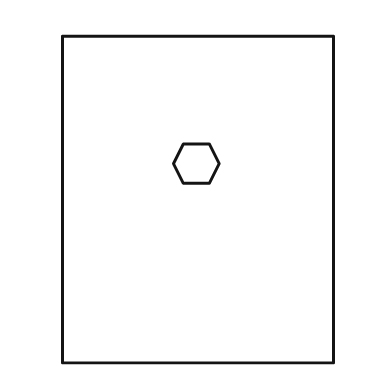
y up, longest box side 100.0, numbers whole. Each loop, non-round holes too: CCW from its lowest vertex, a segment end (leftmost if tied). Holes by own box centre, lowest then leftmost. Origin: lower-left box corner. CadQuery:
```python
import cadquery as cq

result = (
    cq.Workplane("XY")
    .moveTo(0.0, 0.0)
    .lineTo(83.0, 0.0)
    .lineTo(83.0, 100.0)
    .lineTo(0.0, 100.0)
    .close()
    .moveTo(37.0, 55.0)
    .lineTo(45.0, 55.0)
    .lineTo(48.0, 61.0)
    .lineTo(45.0, 67.0)
    .lineTo(37.0, 67.0)
    .lineTo(34.0, 61.0)
    .close()
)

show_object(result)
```